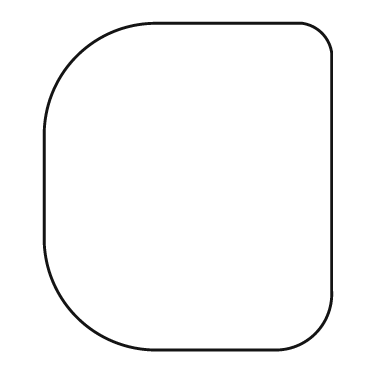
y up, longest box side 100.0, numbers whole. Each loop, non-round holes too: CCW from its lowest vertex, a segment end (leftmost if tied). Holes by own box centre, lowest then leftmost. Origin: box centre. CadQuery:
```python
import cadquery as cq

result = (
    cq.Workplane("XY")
    .moveTo(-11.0, -50.0)
    .lineTo(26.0, -50.0)
    .threePointArc((39.0, -45.0), (44.0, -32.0))
    .lineTo(44.0, 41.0)
    .threePointArc((41.0, 47.0), (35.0, 50.0))
    .lineTo(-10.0, 50.0)
    .threePointArc((-34.0, 40.0), (-44.0, 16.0))
    .lineTo(-44.0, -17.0)
    .threePointArc((-34.0, -40.0), (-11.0, -50.0))
    .close()
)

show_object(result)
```